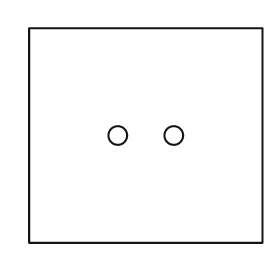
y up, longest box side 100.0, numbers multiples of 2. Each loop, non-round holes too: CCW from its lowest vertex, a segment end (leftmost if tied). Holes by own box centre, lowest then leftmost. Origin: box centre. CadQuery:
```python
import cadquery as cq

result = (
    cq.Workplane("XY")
    .moveTo(-50.0, -46.0)
    .lineTo(50.0, -46.0)
    .lineTo(50.0, 46.0)
    .lineTo(-50.0, 46.0)
    .close()
    .moveTo(-12.0, 0.0)
    .circle(4.0)
    .moveTo(12.0, 0.0)
    .circle(4.0)
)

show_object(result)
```